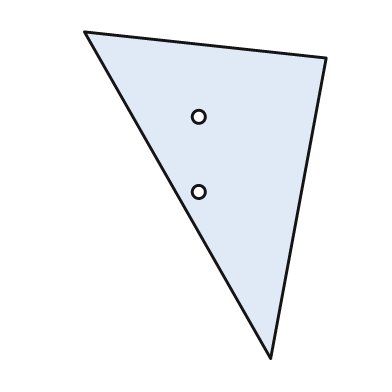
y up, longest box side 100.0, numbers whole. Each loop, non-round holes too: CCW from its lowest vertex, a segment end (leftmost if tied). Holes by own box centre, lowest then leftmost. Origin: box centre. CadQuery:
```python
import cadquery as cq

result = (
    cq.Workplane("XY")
    .moveTo(20.0, -50.0)
    .lineTo(37.0, 42.0)
    .lineTo(-37.0, 50.0)
    .close()
    .moveTo(-2.0, 1.0)
    .circle(2.0)
    .moveTo(-2.0, 24.0)
    .circle(2.0)
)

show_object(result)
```